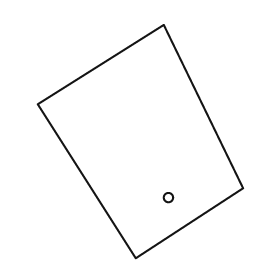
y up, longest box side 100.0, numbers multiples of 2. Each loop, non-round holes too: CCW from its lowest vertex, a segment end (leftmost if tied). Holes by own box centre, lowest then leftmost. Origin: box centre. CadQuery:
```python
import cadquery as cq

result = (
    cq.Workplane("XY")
    .moveTo(-2.0, -50.0)
    .lineTo(44.0, -20.0)
    .lineTo(10.0, 50.0)
    .lineTo(-44.0, 16.0)
    .close()
    .moveTo(12.0, -24.0)
    .circle(2.0)
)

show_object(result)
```